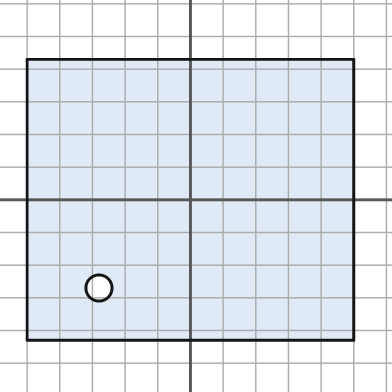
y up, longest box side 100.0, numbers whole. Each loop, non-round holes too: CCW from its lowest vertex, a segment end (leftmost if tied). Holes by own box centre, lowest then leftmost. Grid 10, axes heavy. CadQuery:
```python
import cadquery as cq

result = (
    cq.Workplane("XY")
    .moveTo(-50.0, -43.0)
    .lineTo(50.0, -43.0)
    .lineTo(50.0, 43.0)
    .lineTo(-50.0, 43.0)
    .close()
    .moveTo(-28.0, -27.0)
    .circle(4.0)
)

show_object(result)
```